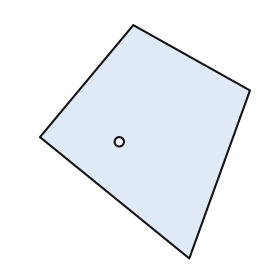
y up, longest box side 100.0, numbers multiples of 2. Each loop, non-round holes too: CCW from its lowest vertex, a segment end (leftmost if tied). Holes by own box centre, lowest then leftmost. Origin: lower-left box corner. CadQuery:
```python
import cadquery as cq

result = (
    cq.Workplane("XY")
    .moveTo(64.0, 0.0)
    .lineTo(90.0, 72.0)
    .lineTo(40.0, 100.0)
    .lineTo(0.0, 52.0)
    .close()
    .moveTo(34.0, 50.0)
    .circle(2.0)
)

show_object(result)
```